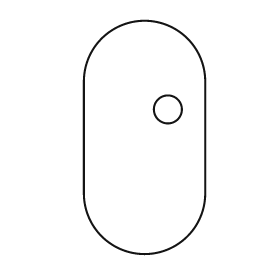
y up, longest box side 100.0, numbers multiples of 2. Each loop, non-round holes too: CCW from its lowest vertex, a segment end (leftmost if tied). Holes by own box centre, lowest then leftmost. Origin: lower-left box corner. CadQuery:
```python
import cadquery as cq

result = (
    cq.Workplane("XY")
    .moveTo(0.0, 26.0)
    .threePointArc((26.0, 0.0), (52.0, 26.0))
    .lineTo(52.0, 74.0)
    .threePointArc((26.0, 100.0), (0.0, 74.0))
    .close()
    .moveTo(36.0, 62.0)
    .circle(6.0)
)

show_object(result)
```